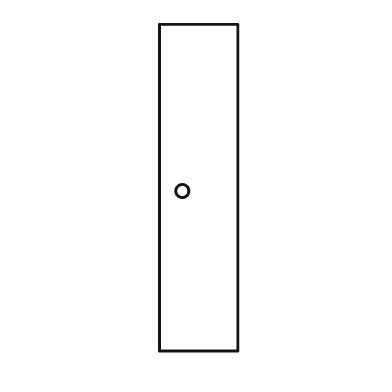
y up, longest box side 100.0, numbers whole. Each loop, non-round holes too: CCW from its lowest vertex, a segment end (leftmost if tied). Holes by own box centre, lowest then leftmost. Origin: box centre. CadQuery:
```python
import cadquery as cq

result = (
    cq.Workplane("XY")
    .moveTo(-12.0, -50.0)
    .lineTo(12.0, -50.0)
    .lineTo(12.0, 50.0)
    .lineTo(-12.0, 50.0)
    .close()
    .moveTo(-5.0, -1.0)
    .circle(2.0)
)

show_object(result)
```